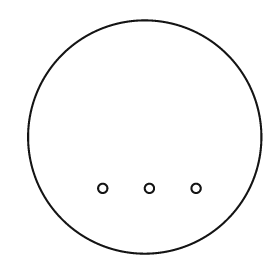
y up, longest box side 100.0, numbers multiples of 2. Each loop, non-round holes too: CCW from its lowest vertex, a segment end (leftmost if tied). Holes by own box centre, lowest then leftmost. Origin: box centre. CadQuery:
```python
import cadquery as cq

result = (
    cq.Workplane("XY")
    .moveTo(0.0, 0.0)
    .circle(50.0)
    .moveTo(-18.0, -22.0)
    .circle(2.0)
    .moveTo(2.0, -22.0)
    .circle(2.0)
    .moveTo(22.0, -22.0)
    .circle(2.0)
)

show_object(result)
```